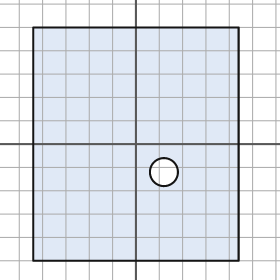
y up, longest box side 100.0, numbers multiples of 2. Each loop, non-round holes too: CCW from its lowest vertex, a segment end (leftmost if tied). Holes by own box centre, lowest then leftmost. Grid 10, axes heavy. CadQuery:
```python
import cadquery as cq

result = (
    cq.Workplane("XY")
    .moveTo(-44.0, -50.0)
    .lineTo(44.0, -50.0)
    .lineTo(44.0, 50.0)
    .lineTo(-44.0, 50.0)
    .close()
    .moveTo(12.0, -12.0)
    .circle(6.0)
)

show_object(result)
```